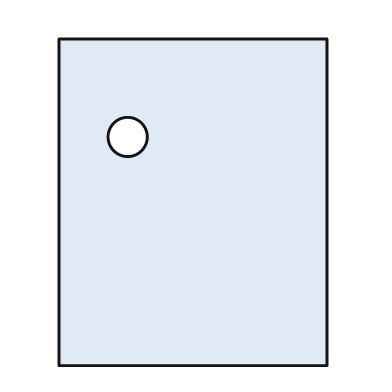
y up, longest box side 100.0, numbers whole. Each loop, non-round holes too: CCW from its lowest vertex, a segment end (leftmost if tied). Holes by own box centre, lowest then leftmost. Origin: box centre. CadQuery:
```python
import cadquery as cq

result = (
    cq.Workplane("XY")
    .moveTo(-41.0, -50.0)
    .lineTo(41.0, -50.0)
    .lineTo(41.0, 50.0)
    .lineTo(-41.0, 50.0)
    .close()
    .moveTo(-20.0, 20.0)
    .circle(6.0)
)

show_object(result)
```